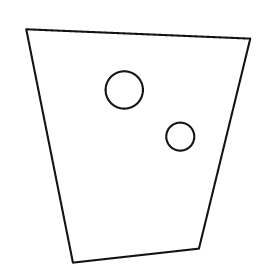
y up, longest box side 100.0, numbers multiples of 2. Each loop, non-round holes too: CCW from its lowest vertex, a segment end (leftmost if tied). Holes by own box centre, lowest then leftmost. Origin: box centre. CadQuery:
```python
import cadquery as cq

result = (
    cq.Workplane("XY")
    .moveTo(-28.0, -50.0)
    .lineTo(26.0, -44.0)
    .lineTo(48.0, 46.0)
    .lineTo(-48.0, 50.0)
    .close()
    .moveTo(18.0, 4.0)
    .circle(6.0)
    .moveTo(-6.0, 24.0)
    .circle(8.0)
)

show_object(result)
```